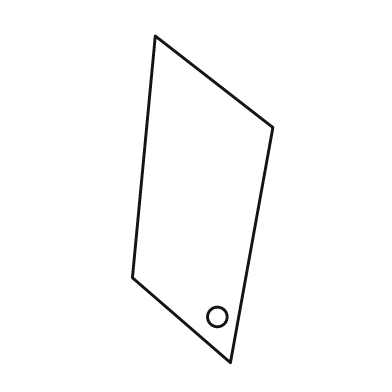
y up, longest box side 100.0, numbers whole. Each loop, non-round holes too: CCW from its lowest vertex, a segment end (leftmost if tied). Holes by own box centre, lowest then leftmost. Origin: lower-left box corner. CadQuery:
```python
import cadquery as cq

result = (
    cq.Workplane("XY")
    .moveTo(30.0, 0.0)
    .lineTo(43.0, 72.0)
    .lineTo(7.0, 100.0)
    .lineTo(0.0, 26.0)
    .close()
    .moveTo(26.0, 14.0)
    .circle(3.0)
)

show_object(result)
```